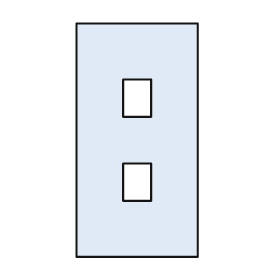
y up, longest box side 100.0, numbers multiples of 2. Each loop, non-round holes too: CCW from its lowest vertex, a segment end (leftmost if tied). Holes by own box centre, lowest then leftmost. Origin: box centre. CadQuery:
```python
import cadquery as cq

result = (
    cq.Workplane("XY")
    .moveTo(-26.0, -50.0)
    .lineTo(26.0, -50.0)
    .lineTo(26.0, 50.0)
    .lineTo(-26.0, 50.0)
    .close()
    .moveTo(-6.0, -26.0)
    .lineTo(6.0, -26.0)
    .lineTo(6.0, -10.0)
    .lineTo(-6.0, -10.0)
    .close()
    .moveTo(-6.0, 10.0)
    .lineTo(6.0, 10.0)
    .lineTo(6.0, 26.0)
    .lineTo(-6.0, 26.0)
    .close()
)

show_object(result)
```